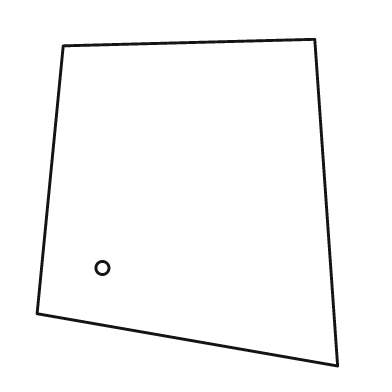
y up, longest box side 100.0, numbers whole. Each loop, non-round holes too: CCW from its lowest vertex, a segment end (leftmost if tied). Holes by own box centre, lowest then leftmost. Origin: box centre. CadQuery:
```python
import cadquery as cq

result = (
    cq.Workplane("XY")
    .moveTo(46.0, -50.0)
    .lineTo(39.0, 50.0)
    .lineTo(-38.0, 48.0)
    .lineTo(-46.0, -34.0)
    .close()
    .moveTo(-26.0, -20.0)
    .circle(2.0)
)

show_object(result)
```